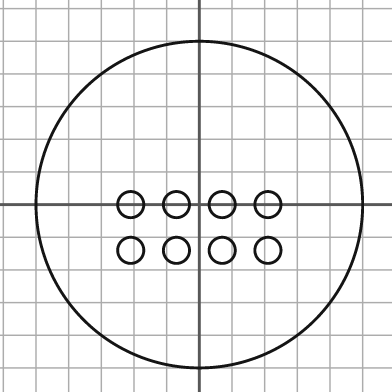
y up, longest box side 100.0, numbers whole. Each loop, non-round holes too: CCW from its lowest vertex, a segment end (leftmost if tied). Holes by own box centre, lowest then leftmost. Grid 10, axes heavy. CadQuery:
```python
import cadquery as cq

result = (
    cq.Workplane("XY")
    .moveTo(0.0, 0.0)
    .circle(50.0)
    .moveTo(-21.0, -14.0)
    .circle(4.0)
    .moveTo(-7.0, -14.0)
    .circle(4.0)
    .moveTo(7.0, -14.0)
    .circle(4.0)
    .moveTo(21.0, -14.0)
    .circle(4.0)
    .moveTo(-21.0, 0.0)
    .circle(4.0)
    .moveTo(-7.0, 0.0)
    .circle(4.0)
    .moveTo(7.0, 0.0)
    .circle(4.0)
    .moveTo(21.0, 0.0)
    .circle(4.0)
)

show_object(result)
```